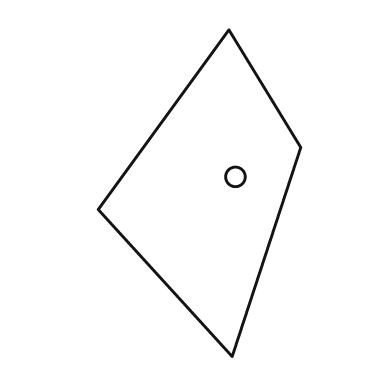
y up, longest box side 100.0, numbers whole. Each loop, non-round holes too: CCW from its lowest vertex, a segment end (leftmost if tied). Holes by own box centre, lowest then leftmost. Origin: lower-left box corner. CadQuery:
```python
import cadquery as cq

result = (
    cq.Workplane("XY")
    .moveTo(41.0, 0.0)
    .lineTo(62.0, 64.0)
    .lineTo(40.0, 100.0)
    .lineTo(0.0, 45.0)
    .close()
    .moveTo(42.0, 55.0)
    .circle(3.0)
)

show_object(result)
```